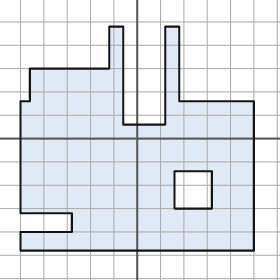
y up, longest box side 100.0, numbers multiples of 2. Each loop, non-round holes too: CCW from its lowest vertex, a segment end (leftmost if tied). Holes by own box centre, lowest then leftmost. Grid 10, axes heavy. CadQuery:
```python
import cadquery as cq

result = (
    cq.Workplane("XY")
    .moveTo(-50.0, -48.0)
    .lineTo(50.0, -48.0)
    .lineTo(50.0, 16.0)
    .lineTo(18.0, 16.0)
    .lineTo(18.0, 48.0)
    .lineTo(12.0, 48.0)
    .lineTo(12.0, 6.0)
    .lineTo(-6.0, 6.0)
    .lineTo(-6.0, 48.0)
    .lineTo(-12.0, 48.0)
    .lineTo(-12.0, 30.0)
    .lineTo(-46.0, 30.0)
    .lineTo(-46.0, 16.0)
    .lineTo(-50.0, 16.0)
    .lineTo(-50.0, -32.0)
    .lineTo(-28.0, -32.0)
    .lineTo(-28.0, -40.0)
    .lineTo(-50.0, -40.0)
    .close()
    .moveTo(16.0, -30.0)
    .lineTo(32.0, -30.0)
    .lineTo(32.0, -14.0)
    .lineTo(16.0, -14.0)
    .close()
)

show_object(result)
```